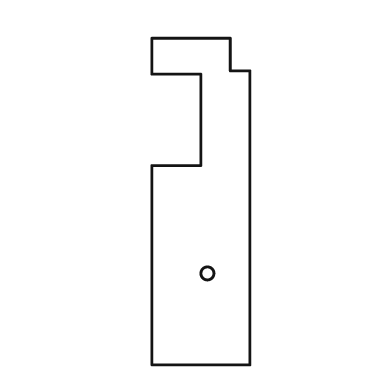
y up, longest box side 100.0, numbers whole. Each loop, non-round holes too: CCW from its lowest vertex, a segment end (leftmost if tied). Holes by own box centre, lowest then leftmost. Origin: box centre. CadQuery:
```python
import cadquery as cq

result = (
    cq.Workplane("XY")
    .moveTo(-15.0, -50.0)
    .lineTo(15.0, -50.0)
    .lineTo(15.0, 40.0)
    .lineTo(9.0, 40.0)
    .lineTo(9.0, 50.0)
    .lineTo(-15.0, 50.0)
    .lineTo(-15.0, 39.0)
    .lineTo(0.0, 39.0)
    .lineTo(0.0, 11.0)
    .lineTo(-15.0, 11.0)
    .close()
    .moveTo(2.0, -22.0)
    .circle(2.0)
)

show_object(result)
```